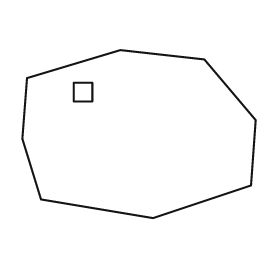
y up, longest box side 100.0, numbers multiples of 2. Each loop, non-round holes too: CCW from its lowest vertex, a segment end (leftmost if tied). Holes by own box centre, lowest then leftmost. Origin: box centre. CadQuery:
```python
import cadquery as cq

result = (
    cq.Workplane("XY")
    .moveTo(6.0, -36.0)
    .lineTo(48.0, -22.0)
    .lineTo(50.0, 6.0)
    .lineTo(28.0, 32.0)
    .lineTo(-8.0, 36.0)
    .lineTo(-48.0, 24.0)
    .lineTo(-50.0, -2.0)
    .lineTo(-42.0, -28.0)
    .close()
    .moveTo(-28.0, 14.0)
    .lineTo(-20.0, 14.0)
    .lineTo(-20.0, 22.0)
    .lineTo(-28.0, 22.0)
    .close()
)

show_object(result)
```